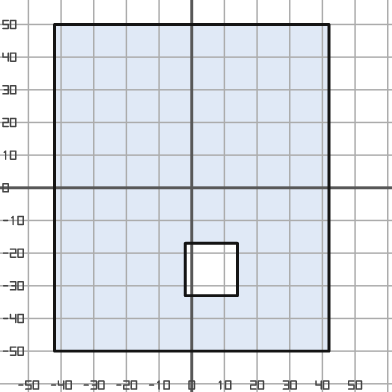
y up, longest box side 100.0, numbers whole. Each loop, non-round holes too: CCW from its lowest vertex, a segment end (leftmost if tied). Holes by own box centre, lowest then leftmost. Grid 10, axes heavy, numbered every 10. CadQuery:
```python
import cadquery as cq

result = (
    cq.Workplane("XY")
    .moveTo(-42.0, -50.0)
    .lineTo(42.0, -50.0)
    .lineTo(42.0, 50.0)
    .lineTo(-42.0, 50.0)
    .close()
    .moveTo(-2.0, -33.0)
    .lineTo(14.0, -33.0)
    .lineTo(14.0, -17.0)
    .lineTo(-2.0, -17.0)
    .close()
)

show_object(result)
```